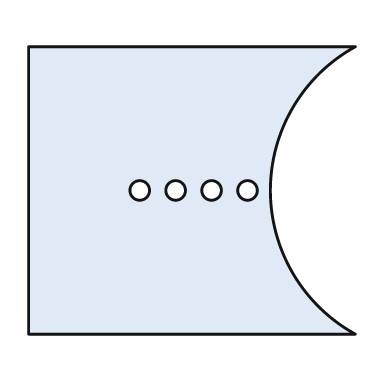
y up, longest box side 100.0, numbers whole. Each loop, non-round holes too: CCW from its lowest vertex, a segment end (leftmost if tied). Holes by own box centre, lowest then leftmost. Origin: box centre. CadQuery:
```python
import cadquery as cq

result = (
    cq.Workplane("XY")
    .moveTo(-50.0, -44.0)
    .lineTo(50.0, -44.0)
    .threePointArc((24.0, 0.0), (50.0, 44.0))
    .lineTo(-50.0, 44.0)
    .close()
    .moveTo(-16.0, 0.0)
    .circle(3.0)
    .moveTo(-5.0, 0.0)
    .circle(3.0)
    .moveTo(6.0, 0.0)
    .circle(3.0)
    .moveTo(17.0, 0.0)
    .circle(3.0)
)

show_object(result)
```